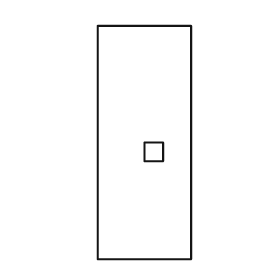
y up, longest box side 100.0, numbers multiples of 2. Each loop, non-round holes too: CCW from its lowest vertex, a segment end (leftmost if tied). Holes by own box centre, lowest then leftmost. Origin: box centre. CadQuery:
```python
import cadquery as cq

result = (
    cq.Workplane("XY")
    .moveTo(-20.0, -50.0)
    .lineTo(20.0, -50.0)
    .lineTo(20.0, 50.0)
    .lineTo(-20.0, 50.0)
    .close()
    .moveTo(0.0, -8.0)
    .lineTo(8.0, -8.0)
    .lineTo(8.0, 0.0)
    .lineTo(0.0, 0.0)
    .close()
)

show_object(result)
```